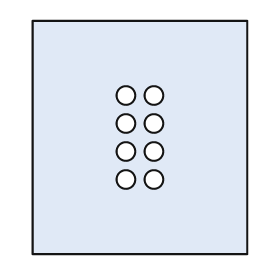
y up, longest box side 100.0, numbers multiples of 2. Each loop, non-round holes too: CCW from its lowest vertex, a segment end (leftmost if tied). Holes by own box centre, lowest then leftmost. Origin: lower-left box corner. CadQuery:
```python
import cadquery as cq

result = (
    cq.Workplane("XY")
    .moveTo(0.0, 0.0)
    .lineTo(92.0, 0.0)
    .lineTo(92.0, 100.0)
    .lineTo(0.0, 100.0)
    .close()
    .moveTo(40.0, 32.0)
    .circle(4.0)
    .moveTo(52.0, 32.0)
    .circle(4.0)
    .moveTo(40.0, 44.0)
    .circle(4.0)
    .moveTo(52.0, 44.0)
    .circle(4.0)
    .moveTo(40.0, 56.0)
    .circle(4.0)
    .moveTo(52.0, 56.0)
    .circle(4.0)
    .moveTo(40.0, 68.0)
    .circle(4.0)
    .moveTo(52.0, 68.0)
    .circle(4.0)
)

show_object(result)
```